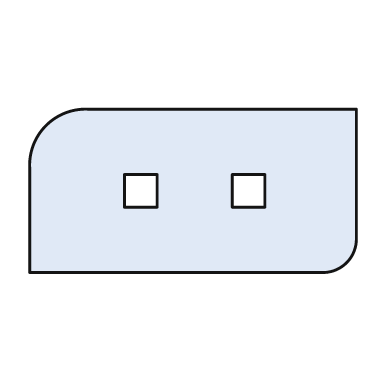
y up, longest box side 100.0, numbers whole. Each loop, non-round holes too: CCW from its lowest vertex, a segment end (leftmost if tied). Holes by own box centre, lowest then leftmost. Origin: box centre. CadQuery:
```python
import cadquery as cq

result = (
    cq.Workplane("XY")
    .moveTo(-50.0, -25.0)
    .lineTo(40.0, -25.0)
    .threePointArc((47.0, -22.0), (50.0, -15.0))
    .lineTo(50.0, 25.0)
    .lineTo(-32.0, 25.0)
    .threePointArc((-45.0, 20.0), (-50.0, 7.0))
    .close()
    .moveTo(-21.0, -5.0)
    .lineTo(-11.0, -5.0)
    .lineTo(-11.0, 5.0)
    .lineTo(-21.0, 5.0)
    .close()
    .moveTo(12.0, -5.0)
    .lineTo(22.0, -5.0)
    .lineTo(22.0, 5.0)
    .lineTo(12.0, 5.0)
    .close()
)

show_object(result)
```